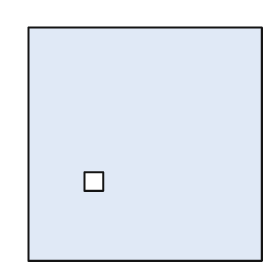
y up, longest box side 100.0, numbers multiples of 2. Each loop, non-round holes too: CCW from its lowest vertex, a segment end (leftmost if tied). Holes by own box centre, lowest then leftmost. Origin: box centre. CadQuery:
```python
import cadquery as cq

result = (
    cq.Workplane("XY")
    .moveTo(-50.0, -50.0)
    .lineTo(50.0, -50.0)
    .lineTo(50.0, 50.0)
    .lineTo(-50.0, 50.0)
    .close()
    .moveTo(-26.0, -20.0)
    .lineTo(-18.0, -20.0)
    .lineTo(-18.0, -12.0)
    .lineTo(-26.0, -12.0)
    .close()
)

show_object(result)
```